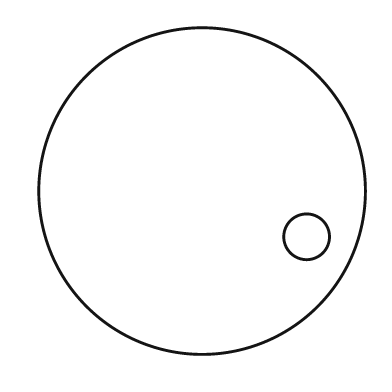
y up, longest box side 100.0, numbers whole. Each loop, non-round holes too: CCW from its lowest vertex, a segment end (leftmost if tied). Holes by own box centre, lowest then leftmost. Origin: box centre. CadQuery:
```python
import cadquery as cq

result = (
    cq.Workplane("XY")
    .moveTo(0.0, 0.0)
    .circle(50.0)
    .moveTo(32.0, -14.0)
    .circle(7.0)
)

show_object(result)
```